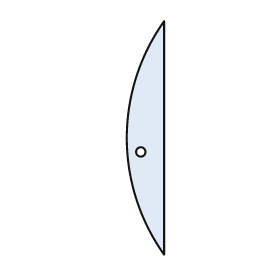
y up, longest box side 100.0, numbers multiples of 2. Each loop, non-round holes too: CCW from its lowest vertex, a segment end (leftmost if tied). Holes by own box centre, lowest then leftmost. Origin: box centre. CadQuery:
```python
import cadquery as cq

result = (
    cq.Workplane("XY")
    .moveTo(8.0, -50.0)
    .lineTo(8.0, 50.0)
    .threePointArc((-8.0, 0.0), (8.0, -50.0))
    .close()
    .moveTo(-2.0, -6.0)
    .circle(2.0)
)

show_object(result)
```